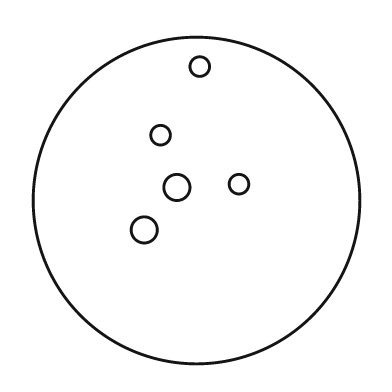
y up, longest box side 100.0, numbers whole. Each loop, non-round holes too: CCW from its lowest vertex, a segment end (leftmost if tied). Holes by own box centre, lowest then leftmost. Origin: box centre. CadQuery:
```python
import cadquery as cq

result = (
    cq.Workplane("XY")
    .moveTo(0.0, 0.0)
    .circle(50.0)
    .moveTo(-16.0, -9.0)
    .circle(4.0)
    .moveTo(-6.0, 4.0)
    .circle(4.0)
    .moveTo(13.0, 5.0)
    .circle(3.0)
    .moveTo(-11.0, 20.0)
    .circle(3.0)
    .moveTo(1.0, 41.0)
    .circle(3.0)
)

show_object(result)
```